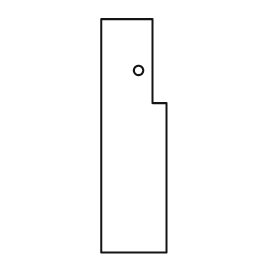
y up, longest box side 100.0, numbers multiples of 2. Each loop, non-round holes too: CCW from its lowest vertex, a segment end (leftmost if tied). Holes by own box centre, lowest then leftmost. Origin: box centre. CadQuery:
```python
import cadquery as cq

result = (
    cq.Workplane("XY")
    .moveTo(-14.0, -50.0)
    .lineTo(14.0, -50.0)
    .lineTo(14.0, 14.0)
    .lineTo(8.0, 14.0)
    .lineTo(8.0, 50.0)
    .lineTo(-14.0, 50.0)
    .close()
    .moveTo(2.0, 28.0)
    .circle(2.0)
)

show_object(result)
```